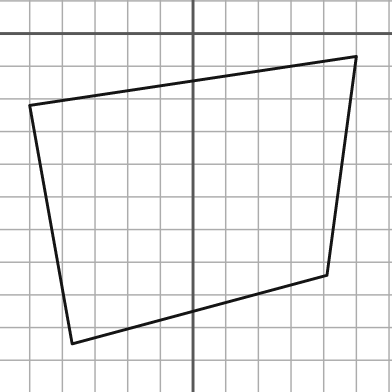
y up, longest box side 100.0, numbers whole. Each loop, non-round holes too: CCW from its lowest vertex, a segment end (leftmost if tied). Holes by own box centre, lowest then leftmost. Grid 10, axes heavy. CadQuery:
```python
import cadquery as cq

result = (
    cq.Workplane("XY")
    .moveTo(-37.0, -95.0)
    .lineTo(41.0, -74.0)
    .lineTo(50.0, -7.0)
    .lineTo(-50.0, -22.0)
    .close()
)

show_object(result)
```